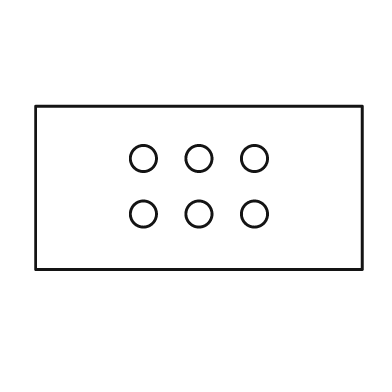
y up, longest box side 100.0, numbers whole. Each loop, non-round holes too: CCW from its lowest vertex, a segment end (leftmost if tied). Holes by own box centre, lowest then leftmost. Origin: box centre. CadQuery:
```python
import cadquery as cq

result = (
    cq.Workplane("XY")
    .moveTo(-50.0, -25.0)
    .lineTo(50.0, -25.0)
    .lineTo(50.0, 25.0)
    .lineTo(-50.0, 25.0)
    .close()
    .moveTo(-17.0, -8.0)
    .circle(4.0)
    .moveTo(0.0, -8.0)
    .circle(4.0)
    .moveTo(17.0, -8.0)
    .circle(4.0)
    .moveTo(-17.0, 9.0)
    .circle(4.0)
    .moveTo(0.0, 9.0)
    .circle(4.0)
    .moveTo(17.0, 9.0)
    .circle(4.0)
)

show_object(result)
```